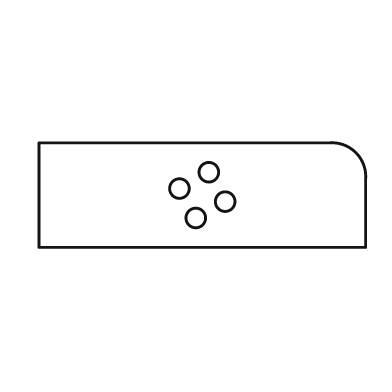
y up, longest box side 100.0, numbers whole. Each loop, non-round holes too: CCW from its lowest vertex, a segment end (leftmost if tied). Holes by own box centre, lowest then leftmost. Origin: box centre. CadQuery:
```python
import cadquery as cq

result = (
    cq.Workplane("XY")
    .moveTo(-50.0, -16.0)
    .lineTo(50.0, -16.0)
    .lineTo(50.0, 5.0)
    .threePointArc((47.0, 13.0), (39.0, 16.0))
    .lineTo(-50.0, 16.0)
    .close()
    .moveTo(-2.0, -7.0)
    .circle(3.0)
    .moveTo(7.0, -2.0)
    .circle(3.0)
    .moveTo(-7.0, 2.0)
    .circle(3.0)
    .moveTo(2.0, 7.0)
    .circle(3.0)
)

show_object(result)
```